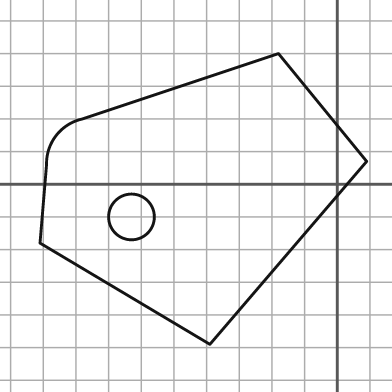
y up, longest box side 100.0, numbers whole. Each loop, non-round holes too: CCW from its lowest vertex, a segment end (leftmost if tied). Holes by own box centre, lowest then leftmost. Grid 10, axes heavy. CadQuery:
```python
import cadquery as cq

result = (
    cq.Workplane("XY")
    .moveTo(-39.0, -49.0)
    .lineTo(9.0, 7.0)
    .lineTo(-18.0, 40.0)
    .lineTo(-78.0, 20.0)
    .threePointArc((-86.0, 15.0), (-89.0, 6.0))
    .lineTo(-91.0, -18.0)
    .close()
    .moveTo(-63.0, -10.0)
    .circle(7.0)
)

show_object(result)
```